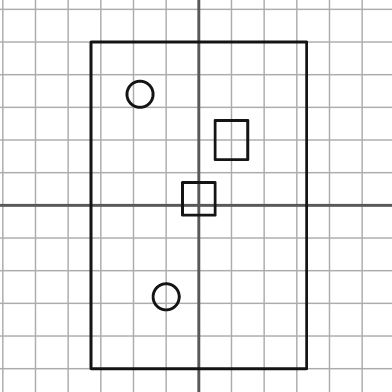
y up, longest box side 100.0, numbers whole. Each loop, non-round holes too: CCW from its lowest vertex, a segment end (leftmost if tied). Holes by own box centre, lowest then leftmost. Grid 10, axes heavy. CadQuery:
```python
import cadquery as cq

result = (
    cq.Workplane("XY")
    .moveTo(-33.0, -50.0)
    .lineTo(33.0, -50.0)
    .lineTo(33.0, 50.0)
    .lineTo(-33.0, 50.0)
    .close()
    .moveTo(-10.0, -28.0)
    .circle(4.0)
    .moveTo(-5.0, -3.0)
    .lineTo(5.0, -3.0)
    .lineTo(5.0, 7.0)
    .lineTo(-5.0, 7.0)
    .close()
    .moveTo(5.0, 14.0)
    .lineTo(15.0, 14.0)
    .lineTo(15.0, 26.0)
    .lineTo(5.0, 26.0)
    .close()
    .moveTo(-18.0, 34.0)
    .circle(4.0)
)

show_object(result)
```